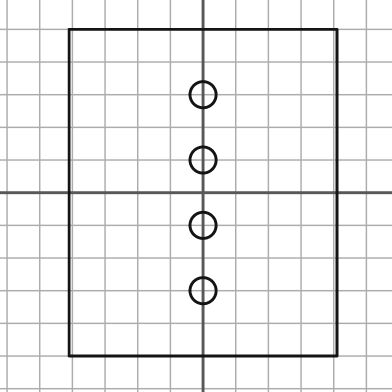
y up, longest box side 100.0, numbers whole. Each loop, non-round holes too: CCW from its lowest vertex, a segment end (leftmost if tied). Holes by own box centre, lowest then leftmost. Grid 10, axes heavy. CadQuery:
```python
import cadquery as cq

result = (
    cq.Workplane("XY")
    .moveTo(-41.0, -50.0)
    .lineTo(41.0, -50.0)
    .lineTo(41.0, 50.0)
    .lineTo(-41.0, 50.0)
    .close()
    .moveTo(0.0, -30.0)
    .circle(4.0)
    .moveTo(0.0, -10.0)
    .circle(4.0)
    .moveTo(0.0, 10.0)
    .circle(4.0)
    .moveTo(0.0, 30.0)
    .circle(4.0)
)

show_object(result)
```